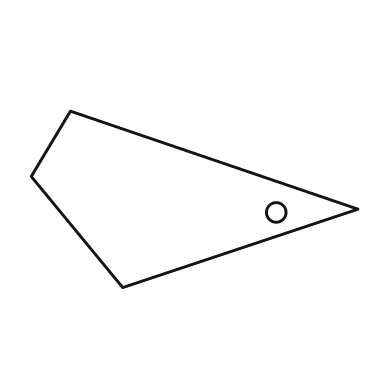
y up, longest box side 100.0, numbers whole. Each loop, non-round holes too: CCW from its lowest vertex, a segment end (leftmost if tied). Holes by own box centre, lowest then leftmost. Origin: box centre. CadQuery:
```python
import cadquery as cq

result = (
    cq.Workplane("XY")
    .moveTo(-22.0, -27.0)
    .lineTo(50.0, -3.0)
    .lineTo(-38.0, 27.0)
    .lineTo(-50.0, 7.0)
    .close()
    .moveTo(25.0, -4.0)
    .circle(3.0)
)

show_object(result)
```